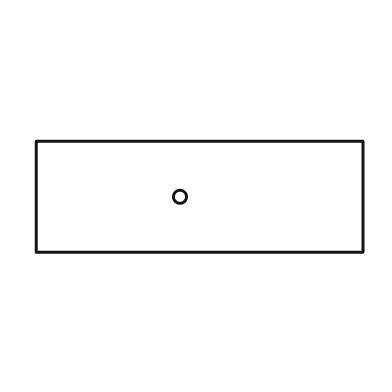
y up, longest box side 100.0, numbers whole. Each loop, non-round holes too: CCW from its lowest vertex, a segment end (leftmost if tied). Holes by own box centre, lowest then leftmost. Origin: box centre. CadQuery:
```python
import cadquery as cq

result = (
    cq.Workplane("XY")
    .moveTo(-50.0, -17.0)
    .lineTo(50.0, -17.0)
    .lineTo(50.0, 17.0)
    .lineTo(-50.0, 17.0)
    .close()
    .moveTo(-6.0, 0.0)
    .circle(2.0)
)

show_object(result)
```